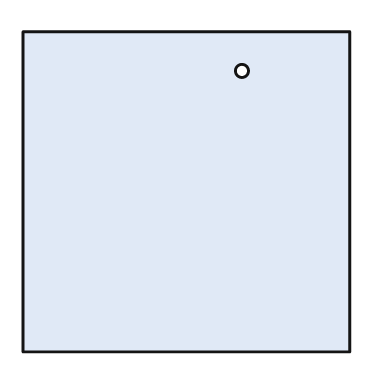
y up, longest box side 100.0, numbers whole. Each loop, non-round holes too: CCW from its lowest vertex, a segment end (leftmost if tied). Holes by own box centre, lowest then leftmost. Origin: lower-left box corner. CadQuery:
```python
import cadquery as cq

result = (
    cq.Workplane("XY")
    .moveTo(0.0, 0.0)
    .lineTo(100.0, 0.0)
    .lineTo(100.0, 98.0)
    .lineTo(0.0, 98.0)
    .close()
    .moveTo(67.0, 86.0)
    .circle(2.0)
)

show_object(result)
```